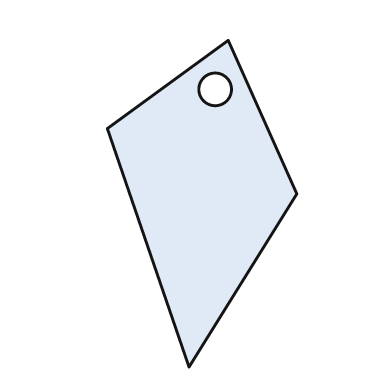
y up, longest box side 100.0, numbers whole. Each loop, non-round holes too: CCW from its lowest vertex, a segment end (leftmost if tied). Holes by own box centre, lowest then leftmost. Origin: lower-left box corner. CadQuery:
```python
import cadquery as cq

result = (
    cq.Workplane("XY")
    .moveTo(25.0, 0.0)
    .lineTo(58.0, 53.0)
    .lineTo(37.0, 100.0)
    .lineTo(0.0, 73.0)
    .close()
    .moveTo(33.0, 85.0)
    .circle(5.0)
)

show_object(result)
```